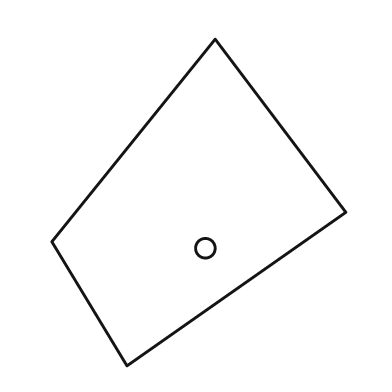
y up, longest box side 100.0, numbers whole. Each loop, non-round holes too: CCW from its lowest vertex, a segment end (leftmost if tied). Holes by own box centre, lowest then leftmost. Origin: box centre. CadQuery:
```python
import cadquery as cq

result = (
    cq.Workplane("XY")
    .moveTo(-22.0, -50.0)
    .lineTo(45.0, -3.0)
    .lineTo(5.0, 50.0)
    .lineTo(-45.0, -12.0)
    .close()
    .moveTo(2.0, -14.0)
    .circle(3.0)
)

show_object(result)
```